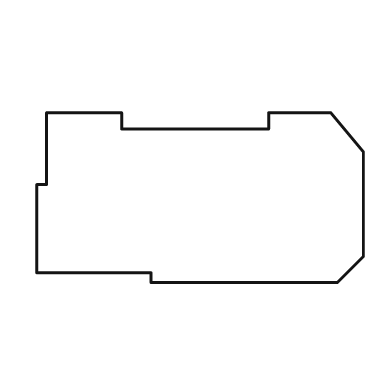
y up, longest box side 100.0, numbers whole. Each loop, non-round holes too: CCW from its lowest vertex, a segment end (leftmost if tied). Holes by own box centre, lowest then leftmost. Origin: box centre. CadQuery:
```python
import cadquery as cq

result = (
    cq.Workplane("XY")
    .moveTo(-15.0, -26.0)
    .lineTo(42.0, -26.0)
    .lineTo(50.0, -18.0)
    .lineTo(50.0, 14.0)
    .lineTo(40.0, 26.0)
    .lineTo(21.0, 26.0)
    .lineTo(21.0, 21.0)
    .lineTo(-24.0, 21.0)
    .lineTo(-24.0, 26.0)
    .lineTo(-47.0, 26.0)
    .lineTo(-47.0, 4.0)
    .lineTo(-50.0, 4.0)
    .lineTo(-50.0, -23.0)
    .lineTo(-15.0, -23.0)
    .close()
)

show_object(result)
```